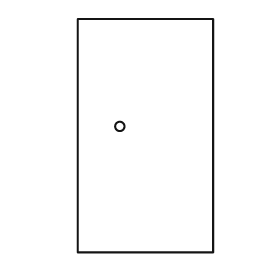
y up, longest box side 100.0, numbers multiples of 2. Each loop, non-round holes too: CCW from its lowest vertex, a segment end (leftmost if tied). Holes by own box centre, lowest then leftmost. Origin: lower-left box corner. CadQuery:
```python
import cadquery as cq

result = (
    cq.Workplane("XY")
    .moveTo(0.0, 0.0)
    .lineTo(58.0, 0.0)
    .lineTo(58.0, 100.0)
    .lineTo(0.0, 100.0)
    .close()
    .moveTo(18.0, 54.0)
    .circle(2.0)
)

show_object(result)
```